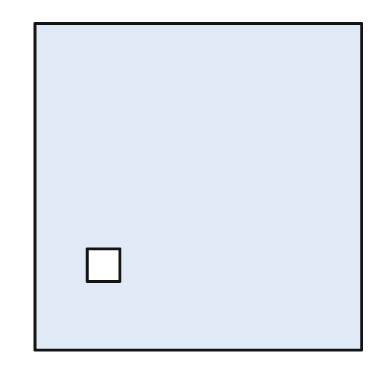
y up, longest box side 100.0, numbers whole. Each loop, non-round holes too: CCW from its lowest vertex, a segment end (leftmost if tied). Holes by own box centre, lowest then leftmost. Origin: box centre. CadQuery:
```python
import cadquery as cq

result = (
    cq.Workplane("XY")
    .moveTo(-50.0, -50.0)
    .lineTo(50.0, -50.0)
    .lineTo(50.0, 50.0)
    .lineTo(-50.0, 50.0)
    .close()
    .moveTo(-34.0, -29.0)
    .lineTo(-24.0, -29.0)
    .lineTo(-24.0, -19.0)
    .lineTo(-34.0, -19.0)
    .close()
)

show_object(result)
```